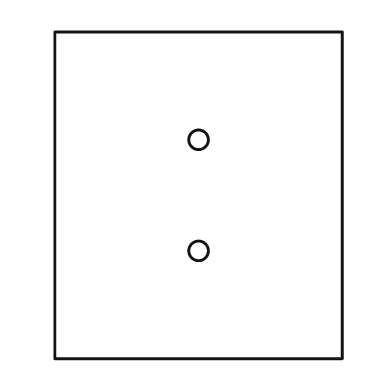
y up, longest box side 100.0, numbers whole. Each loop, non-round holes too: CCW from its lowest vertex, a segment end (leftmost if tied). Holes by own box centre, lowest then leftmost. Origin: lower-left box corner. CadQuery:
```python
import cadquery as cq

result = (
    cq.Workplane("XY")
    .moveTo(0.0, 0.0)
    .lineTo(88.0, 0.0)
    .lineTo(88.0, 100.0)
    .lineTo(0.0, 100.0)
    .close()
    .moveTo(44.0, 33.0)
    .circle(3.0)
    .moveTo(44.0, 67.0)
    .circle(3.0)
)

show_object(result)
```